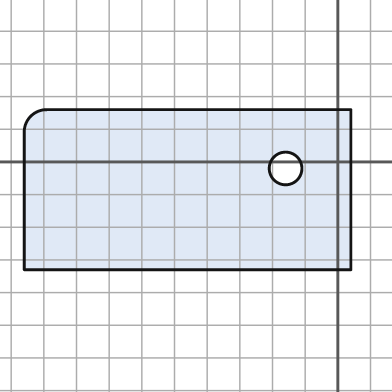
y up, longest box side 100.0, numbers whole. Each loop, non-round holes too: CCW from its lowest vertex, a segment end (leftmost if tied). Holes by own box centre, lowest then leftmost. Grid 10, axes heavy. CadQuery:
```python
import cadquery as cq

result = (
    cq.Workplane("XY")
    .moveTo(-96.0, -33.0)
    .lineTo(4.0, -33.0)
    .lineTo(4.0, 16.0)
    .lineTo(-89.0, 16.0)
    .threePointArc((-94.0, 14.0), (-96.0, 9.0))
    .close()
    .moveTo(-16.0, -2.0)
    .circle(5.0)
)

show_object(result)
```